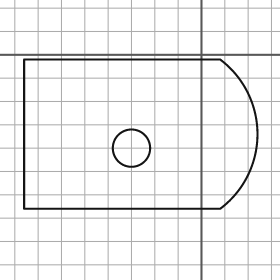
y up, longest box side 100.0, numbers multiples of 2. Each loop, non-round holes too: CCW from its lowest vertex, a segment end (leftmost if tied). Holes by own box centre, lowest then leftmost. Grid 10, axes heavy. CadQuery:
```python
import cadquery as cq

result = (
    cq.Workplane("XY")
    .moveTo(-76.0, -66.0)
    .lineTo(8.0, -66.0)
    .threePointArc((24.0, -34.0), (8.0, -2.0))
    .lineTo(-76.0, -2.0)
    .close()
    .moveTo(-30.0, -40.0)
    .circle(8.0)
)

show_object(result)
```